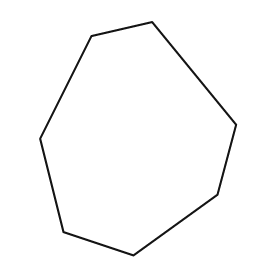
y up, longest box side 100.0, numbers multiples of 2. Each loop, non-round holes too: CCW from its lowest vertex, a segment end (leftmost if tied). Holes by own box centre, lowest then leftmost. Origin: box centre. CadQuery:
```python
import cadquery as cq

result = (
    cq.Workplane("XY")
    .moveTo(-2.0, -50.0)
    .lineTo(34.0, -24.0)
    .lineTo(42.0, 6.0)
    .lineTo(6.0, 50.0)
    .lineTo(-20.0, 44.0)
    .lineTo(-42.0, 0.0)
    .lineTo(-32.0, -40.0)
    .close()
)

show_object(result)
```